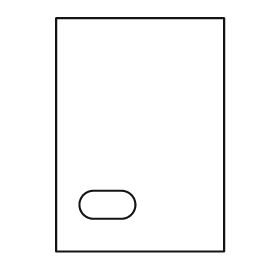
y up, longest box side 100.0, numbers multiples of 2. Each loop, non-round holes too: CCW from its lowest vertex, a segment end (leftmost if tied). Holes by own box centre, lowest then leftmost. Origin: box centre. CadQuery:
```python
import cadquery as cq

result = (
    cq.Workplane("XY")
    .moveTo(-36.0, -50.0)
    .lineTo(36.0, -50.0)
    .lineTo(36.0, 50.0)
    .lineTo(-36.0, 50.0)
    .close()
    .moveTo(-20.0, -36.0)
    .lineTo(-8.0, -36.0)
    .threePointArc((-2.0, -30.0), (-8.0, -24.0))
    .lineTo(-20.0, -24.0)
    .threePointArc((-26.0, -30.0), (-20.0, -36.0))
    .close()
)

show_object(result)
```